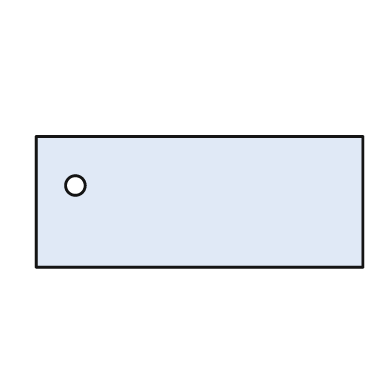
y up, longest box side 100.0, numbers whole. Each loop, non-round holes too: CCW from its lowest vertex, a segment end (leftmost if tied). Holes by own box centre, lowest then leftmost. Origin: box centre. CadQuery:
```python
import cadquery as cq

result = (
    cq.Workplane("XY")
    .moveTo(-50.0, -20.0)
    .lineTo(50.0, -20.0)
    .lineTo(50.0, 20.0)
    .lineTo(-50.0, 20.0)
    .close()
    .moveTo(-38.0, 5.0)
    .circle(3.0)
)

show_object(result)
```